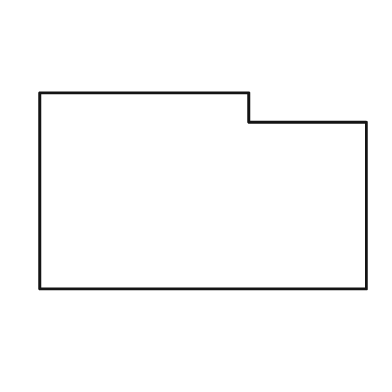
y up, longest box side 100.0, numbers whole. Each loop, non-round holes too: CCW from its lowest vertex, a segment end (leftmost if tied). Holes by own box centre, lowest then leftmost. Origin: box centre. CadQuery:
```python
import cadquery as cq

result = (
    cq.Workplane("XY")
    .moveTo(-50.0, -30.0)
    .lineTo(50.0, -30.0)
    .lineTo(50.0, 21.0)
    .lineTo(14.0, 21.0)
    .lineTo(14.0, 30.0)
    .lineTo(-50.0, 30.0)
    .close()
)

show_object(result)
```